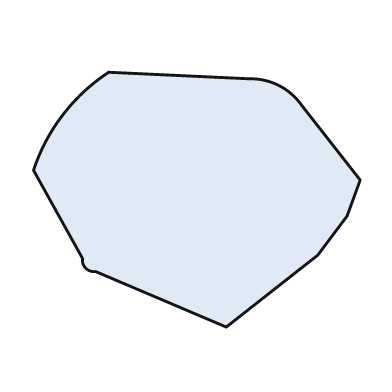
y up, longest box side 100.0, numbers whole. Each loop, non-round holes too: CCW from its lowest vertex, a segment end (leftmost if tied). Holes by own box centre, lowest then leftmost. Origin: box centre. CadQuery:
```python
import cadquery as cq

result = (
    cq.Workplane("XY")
    .moveTo(9.0, -39.0)
    .lineTo(37.0, -17.0)
    .lineTo(46.0, -5.0)
    .lineTo(50.0, 6.0)
    .lineTo(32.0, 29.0)
    .threePointArc((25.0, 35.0), (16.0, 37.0))
    .lineTo(-27.0, 39.0)
    .threePointArc((-41.0, 26.0), (-50.0, 9.0))
    .lineTo(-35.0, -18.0)
    .threePointArc((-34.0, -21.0), (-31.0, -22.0))
    .close()
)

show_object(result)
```